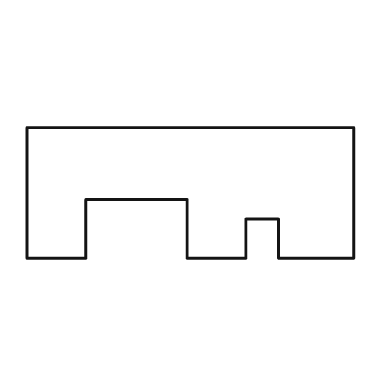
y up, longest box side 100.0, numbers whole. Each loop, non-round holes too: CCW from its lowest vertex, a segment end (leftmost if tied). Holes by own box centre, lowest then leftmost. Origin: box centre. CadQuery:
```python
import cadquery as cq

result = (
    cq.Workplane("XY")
    .moveTo(-50.0, -20.0)
    .lineTo(-32.0, -20.0)
    .lineTo(-32.0, -2.0)
    .lineTo(-1.0, -2.0)
    .lineTo(-1.0, -20.0)
    .lineTo(17.0, -20.0)
    .lineTo(17.0, -8.0)
    .lineTo(27.0, -8.0)
    .lineTo(27.0, -20.0)
    .lineTo(50.0, -20.0)
    .lineTo(50.0, 20.0)
    .lineTo(-50.0, 20.0)
    .close()
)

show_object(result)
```